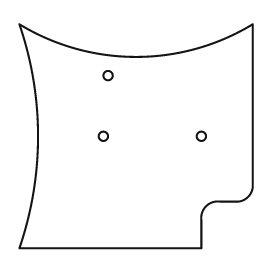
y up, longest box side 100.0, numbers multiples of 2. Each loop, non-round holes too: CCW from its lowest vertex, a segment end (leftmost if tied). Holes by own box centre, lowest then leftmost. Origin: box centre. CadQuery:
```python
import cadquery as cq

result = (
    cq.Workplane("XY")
    .moveTo(-50.0, -48.0)
    .lineTo(28.0, -48.0)
    .lineTo(28.0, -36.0)
    .threePointArc((30.0, -30.0), (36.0, -28.0))
    .lineTo(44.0, -28.0)
    .threePointArc((48.0, -26.0), (50.0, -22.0))
    .lineTo(50.0, 48.0)
    .threePointArc((0.0, 34.0), (-50.0, 48.0))
    .threePointArc((-42.0, 0.0), (-50.0, -48.0))
    .close()
    .moveTo(-14.0, 0.0)
    .circle(2.0)
    .moveTo(28.0, 0.0)
    .circle(2.0)
    .moveTo(-12.0, 26.0)
    .circle(2.0)
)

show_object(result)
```